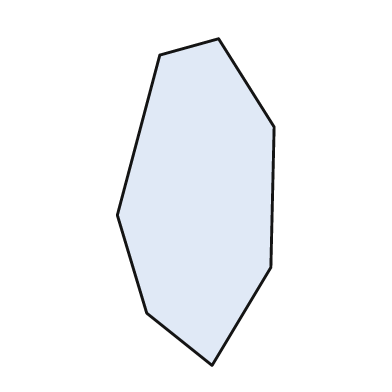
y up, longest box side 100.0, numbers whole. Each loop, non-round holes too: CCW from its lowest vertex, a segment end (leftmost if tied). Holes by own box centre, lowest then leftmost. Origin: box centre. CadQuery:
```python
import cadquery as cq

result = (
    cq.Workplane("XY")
    .moveTo(5.0, -50.0)
    .lineTo(23.0, -20.0)
    .lineTo(24.0, 23.0)
    .lineTo(7.0, 50.0)
    .lineTo(-11.0, 45.0)
    .lineTo(-24.0, -4.0)
    .lineTo(-15.0, -34.0)
    .close()
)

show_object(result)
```